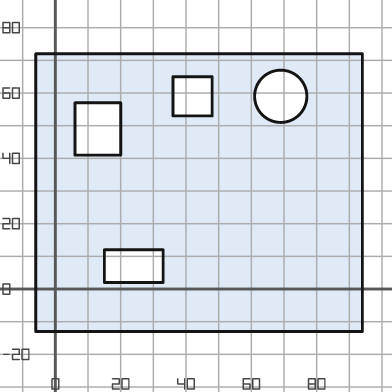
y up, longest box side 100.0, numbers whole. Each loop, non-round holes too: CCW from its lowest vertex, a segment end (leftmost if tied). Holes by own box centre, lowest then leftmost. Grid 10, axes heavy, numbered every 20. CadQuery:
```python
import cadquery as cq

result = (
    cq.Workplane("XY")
    .moveTo(-6.0, -13.0)
    .lineTo(94.0, -13.0)
    .lineTo(94.0, 72.0)
    .lineTo(-6.0, 72.0)
    .close()
    .moveTo(15.0, 2.0)
    .lineTo(33.0, 2.0)
    .lineTo(33.0, 12.0)
    .lineTo(15.0, 12.0)
    .close()
    .moveTo(6.0, 41.0)
    .lineTo(20.0, 41.0)
    .lineTo(20.0, 57.0)
    .lineTo(6.0, 57.0)
    .close()
    .moveTo(36.0, 53.0)
    .lineTo(48.0, 53.0)
    .lineTo(48.0, 65.0)
    .lineTo(36.0, 65.0)
    .close()
    .moveTo(69.0, 59.0)
    .circle(8.0)
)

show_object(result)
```